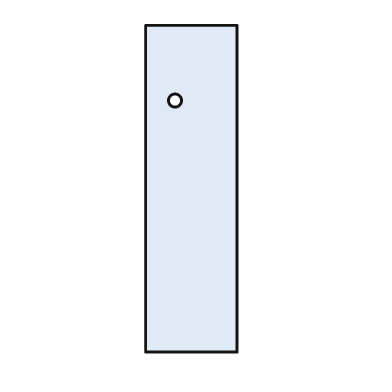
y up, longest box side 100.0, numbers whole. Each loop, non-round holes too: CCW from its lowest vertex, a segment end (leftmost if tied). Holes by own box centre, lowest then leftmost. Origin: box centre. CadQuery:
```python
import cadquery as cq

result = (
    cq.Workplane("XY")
    .moveTo(-14.0, -50.0)
    .lineTo(14.0, -50.0)
    .lineTo(14.0, 50.0)
    .lineTo(-14.0, 50.0)
    .close()
    .moveTo(-5.0, 27.0)
    .circle(2.0)
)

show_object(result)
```